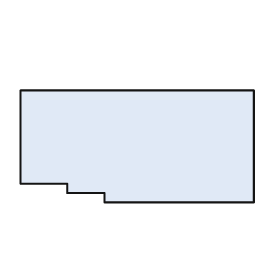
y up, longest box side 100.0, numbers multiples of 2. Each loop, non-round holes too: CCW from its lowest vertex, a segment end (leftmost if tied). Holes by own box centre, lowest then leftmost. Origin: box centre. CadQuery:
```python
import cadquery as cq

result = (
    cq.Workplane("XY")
    .moveTo(-14.0, -24.0)
    .lineTo(50.0, -24.0)
    .lineTo(50.0, 24.0)
    .lineTo(-50.0, 24.0)
    .lineTo(-50.0, -16.0)
    .lineTo(-30.0, -16.0)
    .lineTo(-30.0, -20.0)
    .lineTo(-14.0, -20.0)
    .close()
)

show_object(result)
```